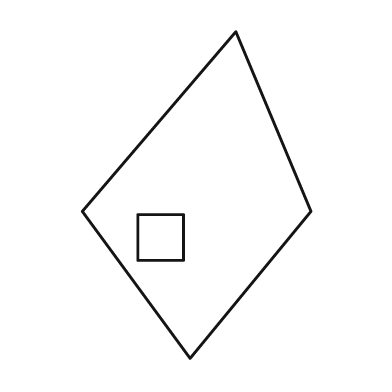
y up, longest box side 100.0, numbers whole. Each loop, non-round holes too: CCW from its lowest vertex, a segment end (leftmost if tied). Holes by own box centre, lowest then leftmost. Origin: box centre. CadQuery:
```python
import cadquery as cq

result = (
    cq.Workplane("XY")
    .moveTo(-2.0, -50.0)
    .lineTo(35.0, -5.0)
    .lineTo(12.0, 50.0)
    .lineTo(-35.0, -5.0)
    .close()
    .moveTo(-18.0, -20.0)
    .lineTo(-4.0, -20.0)
    .lineTo(-4.0, -6.0)
    .lineTo(-18.0, -6.0)
    .close()
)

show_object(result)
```